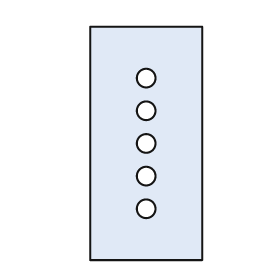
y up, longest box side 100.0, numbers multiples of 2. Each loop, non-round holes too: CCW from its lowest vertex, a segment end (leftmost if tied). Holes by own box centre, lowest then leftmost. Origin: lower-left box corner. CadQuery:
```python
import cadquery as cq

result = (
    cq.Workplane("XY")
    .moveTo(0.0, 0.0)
    .lineTo(48.0, 0.0)
    .lineTo(48.0, 100.0)
    .lineTo(0.0, 100.0)
    .close()
    .moveTo(24.0, 22.0)
    .circle(4.0)
    .moveTo(24.0, 36.0)
    .circle(4.0)
    .moveTo(24.0, 50.0)
    .circle(4.0)
    .moveTo(24.0, 64.0)
    .circle(4.0)
    .moveTo(24.0, 78.0)
    .circle(4.0)
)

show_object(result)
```